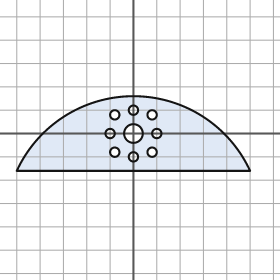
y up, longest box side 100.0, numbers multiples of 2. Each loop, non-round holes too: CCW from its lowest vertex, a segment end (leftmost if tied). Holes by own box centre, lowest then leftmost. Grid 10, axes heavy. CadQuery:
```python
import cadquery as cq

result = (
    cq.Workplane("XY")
    .moveTo(-50.0, -16.0)
    .lineTo(50.0, -16.0)
    .threePointArc((0.0, 16.0), (-50.0, -16.0))
    .close()
    .moveTo(0.0, -10.0)
    .circle(2.0)
    .moveTo(-8.0, -8.0)
    .circle(2.0)
    .moveTo(8.0, -8.0)
    .circle(2.0)
    .moveTo(-10.0, 0.0)
    .circle(2.0)
    .moveTo(0.0, 0.0)
    .circle(4.0)
    .moveTo(10.0, 0.0)
    .circle(2.0)
    .moveTo(-8.0, 8.0)
    .circle(2.0)
    .moveTo(8.0, 8.0)
    .circle(2.0)
    .moveTo(0.0, 10.0)
    .circle(2.0)
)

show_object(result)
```